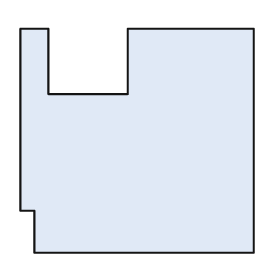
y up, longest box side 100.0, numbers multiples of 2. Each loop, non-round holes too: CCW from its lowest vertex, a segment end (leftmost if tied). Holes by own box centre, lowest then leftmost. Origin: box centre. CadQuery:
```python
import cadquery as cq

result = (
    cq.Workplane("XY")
    .moveTo(-44.0, -48.0)
    .lineTo(50.0, -48.0)
    .lineTo(50.0, 48.0)
    .lineTo(-4.0, 48.0)
    .lineTo(-4.0, 20.0)
    .lineTo(-38.0, 20.0)
    .lineTo(-38.0, 48.0)
    .lineTo(-50.0, 48.0)
    .lineTo(-50.0, -30.0)
    .lineTo(-44.0, -30.0)
    .close()
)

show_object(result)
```